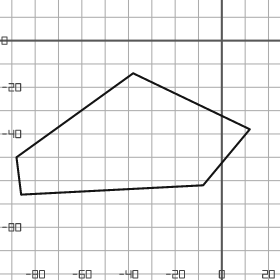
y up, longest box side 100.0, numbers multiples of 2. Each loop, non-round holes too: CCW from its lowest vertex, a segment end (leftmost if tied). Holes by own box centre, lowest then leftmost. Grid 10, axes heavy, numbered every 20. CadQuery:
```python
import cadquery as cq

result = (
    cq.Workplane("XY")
    .moveTo(-86.0, -66.0)
    .lineTo(-8.0, -62.0)
    .lineTo(12.0, -38.0)
    .lineTo(-38.0, -14.0)
    .lineTo(-88.0, -50.0)
    .close()
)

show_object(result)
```